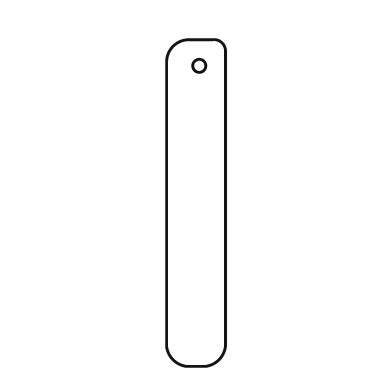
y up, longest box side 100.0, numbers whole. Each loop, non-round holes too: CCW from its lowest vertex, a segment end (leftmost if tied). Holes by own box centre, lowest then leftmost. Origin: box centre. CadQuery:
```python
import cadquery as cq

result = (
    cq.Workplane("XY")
    .moveTo(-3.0, -50.0)
    .lineTo(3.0, -50.0)
    .threePointArc((7.0, -48.0), (9.0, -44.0))
    .lineTo(9.0, 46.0)
    .threePointArc((8.0, 49.0), (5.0, 50.0))
    .lineTo(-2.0, 50.0)
    .threePointArc((-7.0, 48.0), (-9.0, 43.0))
    .lineTo(-9.0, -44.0)
    .threePointArc((-7.0, -48.0), (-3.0, -50.0))
    .close()
    .moveTo(1.0, 42.0)
    .circle(2.0)
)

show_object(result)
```